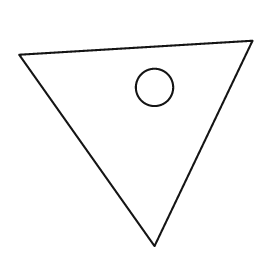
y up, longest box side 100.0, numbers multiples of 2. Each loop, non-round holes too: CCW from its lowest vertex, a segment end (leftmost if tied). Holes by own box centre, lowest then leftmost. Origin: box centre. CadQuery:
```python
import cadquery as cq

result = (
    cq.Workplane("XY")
    .moveTo(8.0, -44.0)
    .lineTo(50.0, 44.0)
    .lineTo(-50.0, 38.0)
    .close()
    .moveTo(8.0, 24.0)
    .circle(8.0)
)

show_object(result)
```